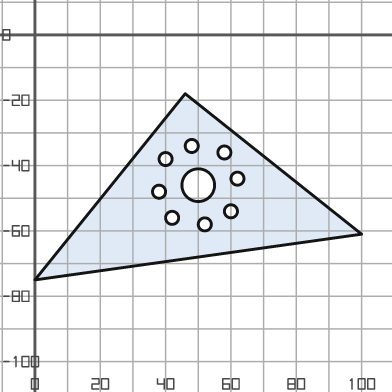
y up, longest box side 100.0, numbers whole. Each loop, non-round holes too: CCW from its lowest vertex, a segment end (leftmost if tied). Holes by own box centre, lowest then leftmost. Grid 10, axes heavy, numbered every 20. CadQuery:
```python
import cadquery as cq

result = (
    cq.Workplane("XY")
    .moveTo(0.0, -75.0)
    .lineTo(100.0, -61.0)
    .lineTo(46.0, -18.0)
    .close()
    .moveTo(52.0, -58.0)
    .circle(2.0)
    .moveTo(42.0, -56.0)
    .circle(2.0)
    .moveTo(60.0, -54.0)
    .circle(2.0)
    .moveTo(38.0, -48.0)
    .circle(2.0)
    .moveTo(50.0, -46.0)
    .circle(5.0)
    .moveTo(62.0, -44.0)
    .circle(2.0)
    .moveTo(40.0, -38.0)
    .circle(2.0)
    .moveTo(58.0, -36.0)
    .circle(2.0)
    .moveTo(48.0, -34.0)
    .circle(2.0)
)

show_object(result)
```